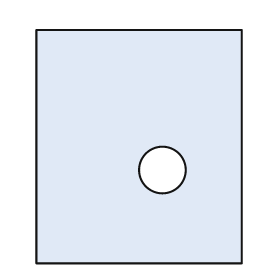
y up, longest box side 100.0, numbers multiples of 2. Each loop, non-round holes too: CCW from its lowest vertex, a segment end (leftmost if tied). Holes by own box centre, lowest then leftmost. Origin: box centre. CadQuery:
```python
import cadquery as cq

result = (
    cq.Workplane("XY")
    .moveTo(-44.0, -50.0)
    .lineTo(44.0, -50.0)
    .lineTo(44.0, 50.0)
    .lineTo(-44.0, 50.0)
    .close()
    .moveTo(10.0, -10.0)
    .circle(10.0)
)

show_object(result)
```